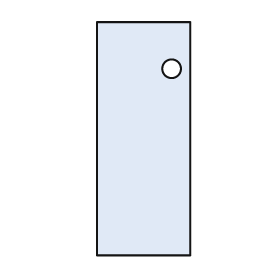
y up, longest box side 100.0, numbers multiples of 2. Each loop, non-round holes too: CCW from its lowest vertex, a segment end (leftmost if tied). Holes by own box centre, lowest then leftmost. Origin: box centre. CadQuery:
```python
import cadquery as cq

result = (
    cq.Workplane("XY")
    .moveTo(-20.0, -50.0)
    .lineTo(20.0, -50.0)
    .lineTo(20.0, 50.0)
    .lineTo(-20.0, 50.0)
    .close()
    .moveTo(12.0, 30.0)
    .circle(4.0)
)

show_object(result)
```